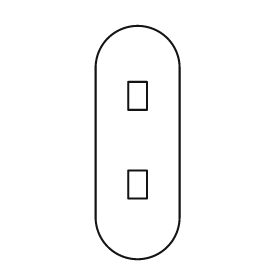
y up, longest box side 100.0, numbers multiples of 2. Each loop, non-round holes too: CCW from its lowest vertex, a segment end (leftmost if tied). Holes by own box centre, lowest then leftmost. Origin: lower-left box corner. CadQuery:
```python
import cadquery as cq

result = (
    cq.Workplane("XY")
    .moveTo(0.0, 18.0)
    .threePointArc((18.0, 0.0), (36.0, 18.0))
    .lineTo(36.0, 82.0)
    .threePointArc((18.0, 100.0), (0.0, 82.0))
    .close()
    .moveTo(14.0, 26.0)
    .lineTo(22.0, 26.0)
    .lineTo(22.0, 38.0)
    .lineTo(14.0, 38.0)
    .close()
    .moveTo(14.0, 64.0)
    .lineTo(22.0, 64.0)
    .lineTo(22.0, 76.0)
    .lineTo(14.0, 76.0)
    .close()
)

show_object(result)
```